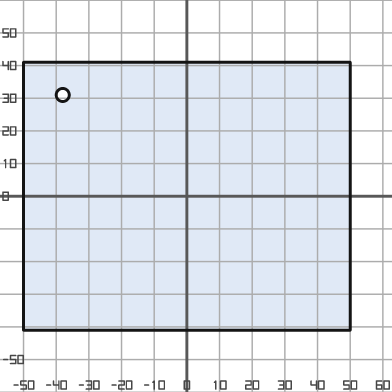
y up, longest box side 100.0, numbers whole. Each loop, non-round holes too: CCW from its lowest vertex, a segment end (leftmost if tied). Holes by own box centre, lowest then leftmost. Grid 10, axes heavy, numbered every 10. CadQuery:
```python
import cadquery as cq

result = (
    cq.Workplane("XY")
    .moveTo(-50.0, -41.0)
    .lineTo(50.0, -41.0)
    .lineTo(50.0, 41.0)
    .lineTo(-50.0, 41.0)
    .close()
    .moveTo(-38.0, 31.0)
    .circle(2.0)
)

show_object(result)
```